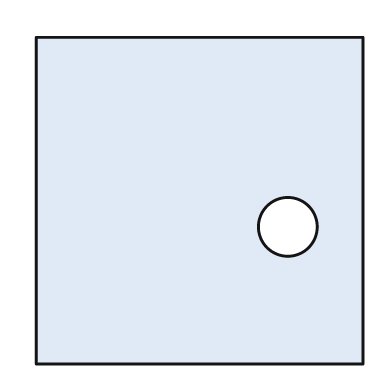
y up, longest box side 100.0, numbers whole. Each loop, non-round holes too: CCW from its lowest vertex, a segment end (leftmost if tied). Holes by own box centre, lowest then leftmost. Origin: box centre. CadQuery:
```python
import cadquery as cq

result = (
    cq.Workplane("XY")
    .moveTo(-50.0, -50.0)
    .lineTo(50.0, -50.0)
    .lineTo(50.0, 50.0)
    .lineTo(-50.0, 50.0)
    .close()
    .moveTo(27.0, -8.0)
    .circle(9.0)
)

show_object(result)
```